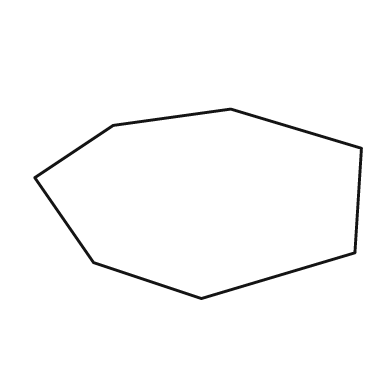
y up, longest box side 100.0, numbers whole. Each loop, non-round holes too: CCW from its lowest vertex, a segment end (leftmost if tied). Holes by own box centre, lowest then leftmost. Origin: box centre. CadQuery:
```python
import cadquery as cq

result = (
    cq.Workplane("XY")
    .moveTo(1.0, -29.0)
    .lineTo(48.0, -15.0)
    .lineTo(50.0, 17.0)
    .lineTo(10.0, 29.0)
    .lineTo(-26.0, 24.0)
    .lineTo(-50.0, 8.0)
    .lineTo(-32.0, -18.0)
    .close()
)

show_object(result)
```